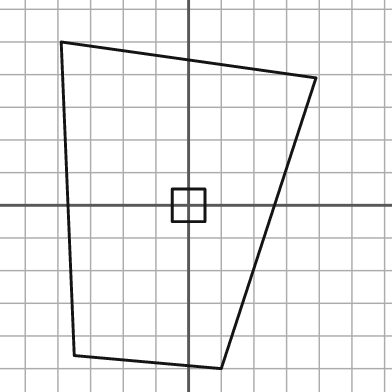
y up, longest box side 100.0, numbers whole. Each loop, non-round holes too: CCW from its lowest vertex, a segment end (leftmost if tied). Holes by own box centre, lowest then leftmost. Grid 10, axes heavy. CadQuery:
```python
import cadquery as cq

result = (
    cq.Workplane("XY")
    .moveTo(10.0, -50.0)
    .lineTo(39.0, 39.0)
    .lineTo(-39.0, 50.0)
    .lineTo(-35.0, -46.0)
    .close()
    .moveTo(-5.0, -5.0)
    .lineTo(5.0, -5.0)
    .lineTo(5.0, 5.0)
    .lineTo(-5.0, 5.0)
    .close()
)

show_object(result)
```